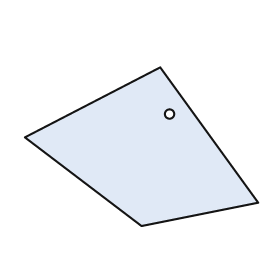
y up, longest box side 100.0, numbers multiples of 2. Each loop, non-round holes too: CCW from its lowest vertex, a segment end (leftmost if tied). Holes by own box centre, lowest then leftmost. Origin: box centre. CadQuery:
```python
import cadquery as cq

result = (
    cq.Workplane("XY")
    .moveTo(0.0, -34.0)
    .lineTo(50.0, -24.0)
    .lineTo(8.0, 34.0)
    .lineTo(-50.0, 4.0)
    .close()
    .moveTo(12.0, 14.0)
    .circle(2.0)
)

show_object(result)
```